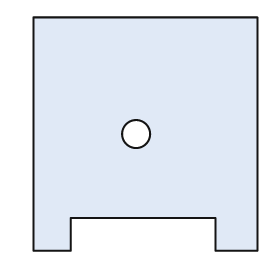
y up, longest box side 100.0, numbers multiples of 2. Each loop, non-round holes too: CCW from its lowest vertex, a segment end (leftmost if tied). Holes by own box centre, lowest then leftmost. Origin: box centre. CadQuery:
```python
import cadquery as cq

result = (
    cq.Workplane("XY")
    .moveTo(-48.0, -50.0)
    .lineTo(-32.0, -50.0)
    .lineTo(-32.0, -36.0)
    .lineTo(30.0, -36.0)
    .lineTo(30.0, -50.0)
    .lineTo(48.0, -50.0)
    .lineTo(48.0, 50.0)
    .lineTo(-48.0, 50.0)
    .close()
    .moveTo(-4.0, 0.0)
    .circle(6.0)
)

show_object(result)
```